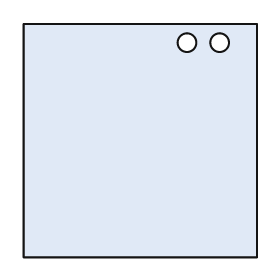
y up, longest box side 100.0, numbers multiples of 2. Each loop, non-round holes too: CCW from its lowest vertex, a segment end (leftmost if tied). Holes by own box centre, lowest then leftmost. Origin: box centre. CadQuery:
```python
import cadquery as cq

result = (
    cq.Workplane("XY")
    .moveTo(-50.0, -50.0)
    .lineTo(50.0, -50.0)
    .lineTo(50.0, 50.0)
    .lineTo(-50.0, 50.0)
    .close()
    .moveTo(20.0, 42.0)
    .circle(4.0)
    .moveTo(34.0, 42.0)
    .circle(4.0)
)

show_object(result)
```